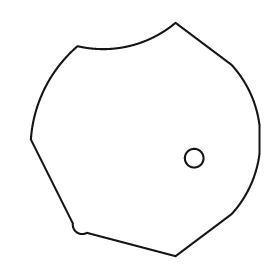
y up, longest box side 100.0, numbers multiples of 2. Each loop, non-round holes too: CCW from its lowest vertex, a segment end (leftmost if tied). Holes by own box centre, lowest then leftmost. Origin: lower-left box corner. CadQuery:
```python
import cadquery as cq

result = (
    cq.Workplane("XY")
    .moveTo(62.0, 0.0)
    .lineTo(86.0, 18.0)
    .threePointArc((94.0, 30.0), (98.0, 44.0))
    .lineTo(98.0, 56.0)
    .threePointArc((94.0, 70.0), (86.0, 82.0))
    .lineTo(62.0, 100.0)
    .threePointArc((42.0, 90.0), (20.0, 90.0))
    .threePointArc((6.0, 72.0), (0.0, 50.0))
    .lineTo(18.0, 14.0)
    .threePointArc((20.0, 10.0), (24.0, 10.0))
    .close()
    .moveTo(70.0, 42.0)
    .circle(4.0)
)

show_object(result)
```